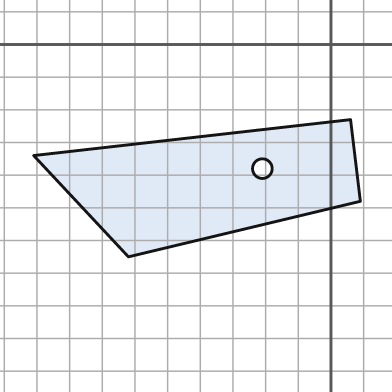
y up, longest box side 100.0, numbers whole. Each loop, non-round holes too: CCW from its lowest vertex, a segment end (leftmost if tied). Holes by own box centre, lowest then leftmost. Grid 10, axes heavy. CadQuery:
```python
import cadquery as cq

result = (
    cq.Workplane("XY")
    .moveTo(-62.0, -65.0)
    .lineTo(9.0, -48.0)
    .lineTo(6.0, -23.0)
    .lineTo(-91.0, -34.0)
    .close()
    .moveTo(-21.0, -38.0)
    .circle(3.0)
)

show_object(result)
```